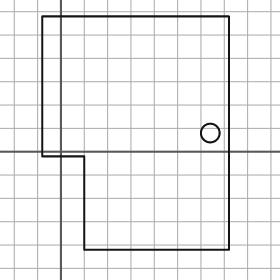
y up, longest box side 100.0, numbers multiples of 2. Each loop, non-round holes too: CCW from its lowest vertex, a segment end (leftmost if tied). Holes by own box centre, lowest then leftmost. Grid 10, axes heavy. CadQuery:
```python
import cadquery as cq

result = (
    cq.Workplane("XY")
    .moveTo(10.0, -42.0)
    .lineTo(72.0, -42.0)
    .lineTo(72.0, 58.0)
    .lineTo(-8.0, 58.0)
    .lineTo(-8.0, -2.0)
    .lineTo(10.0, -2.0)
    .close()
    .moveTo(64.0, 8.0)
    .circle(4.0)
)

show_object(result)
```